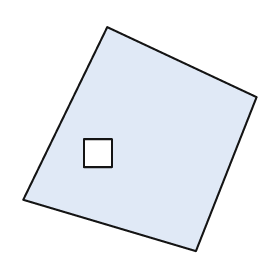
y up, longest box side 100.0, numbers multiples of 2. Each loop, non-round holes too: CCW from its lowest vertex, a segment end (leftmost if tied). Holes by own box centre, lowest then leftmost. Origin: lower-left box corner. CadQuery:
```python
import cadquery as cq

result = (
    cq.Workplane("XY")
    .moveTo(74.0, 0.0)
    .lineTo(100.0, 66.0)
    .lineTo(36.0, 96.0)
    .lineTo(0.0, 22.0)
    .close()
    .moveTo(26.0, 36.0)
    .lineTo(38.0, 36.0)
    .lineTo(38.0, 48.0)
    .lineTo(26.0, 48.0)
    .close()
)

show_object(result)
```